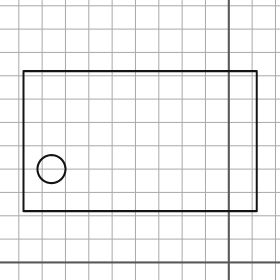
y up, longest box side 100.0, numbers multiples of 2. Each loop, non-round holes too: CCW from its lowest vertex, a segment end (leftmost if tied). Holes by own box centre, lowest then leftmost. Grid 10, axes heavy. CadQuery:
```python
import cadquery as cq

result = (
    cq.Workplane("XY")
    .moveTo(-88.0, 22.0)
    .lineTo(12.0, 22.0)
    .lineTo(12.0, 82.0)
    .lineTo(-88.0, 82.0)
    .close()
    .moveTo(-76.0, 40.0)
    .circle(6.0)
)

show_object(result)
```